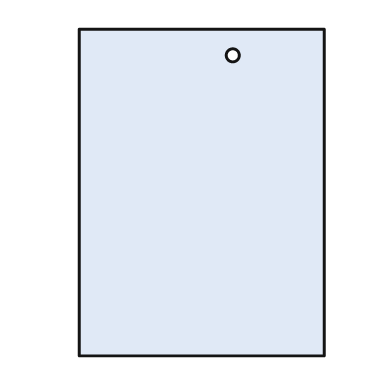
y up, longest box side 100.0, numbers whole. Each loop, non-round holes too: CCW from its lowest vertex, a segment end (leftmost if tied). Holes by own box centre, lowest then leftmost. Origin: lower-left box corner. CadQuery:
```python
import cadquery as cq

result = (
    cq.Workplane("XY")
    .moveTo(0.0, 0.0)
    .lineTo(75.0, 0.0)
    .lineTo(75.0, 100.0)
    .lineTo(0.0, 100.0)
    .close()
    .moveTo(47.0, 92.0)
    .circle(2.0)
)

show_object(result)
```